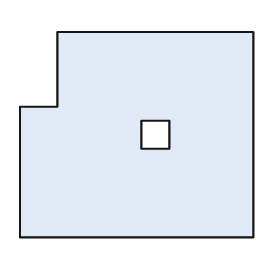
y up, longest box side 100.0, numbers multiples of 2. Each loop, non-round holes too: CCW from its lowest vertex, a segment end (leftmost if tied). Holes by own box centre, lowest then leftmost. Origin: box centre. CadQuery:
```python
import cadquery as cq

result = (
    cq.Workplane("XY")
    .moveTo(-50.0, -44.0)
    .lineTo(50.0, -44.0)
    .lineTo(50.0, 44.0)
    .lineTo(-34.0, 44.0)
    .lineTo(-34.0, 12.0)
    .lineTo(-50.0, 12.0)
    .close()
    .moveTo(2.0, -6.0)
    .lineTo(14.0, -6.0)
    .lineTo(14.0, 6.0)
    .lineTo(2.0, 6.0)
    .close()
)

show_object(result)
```